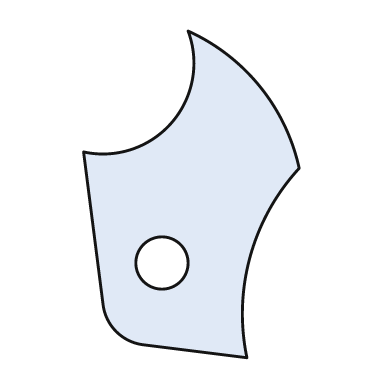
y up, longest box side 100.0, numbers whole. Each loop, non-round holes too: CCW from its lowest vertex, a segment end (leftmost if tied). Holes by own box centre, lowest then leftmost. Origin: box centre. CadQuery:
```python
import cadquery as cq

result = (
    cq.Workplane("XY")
    .moveTo(17.0, -50.0)
    .threePointArc((18.0, -19.0), (33.0, 8.0))
    .threePointArc((21.0, 33.0), (-1.0, 50.0))
    .threePointArc((-6.0, 22.0), (-33.0, 13.0))
    .lineTo(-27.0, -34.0)
    .threePointArc((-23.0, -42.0), (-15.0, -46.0))
    .close()
    .moveTo(-9.0, -21.0)
    .circle(8.0)
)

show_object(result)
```